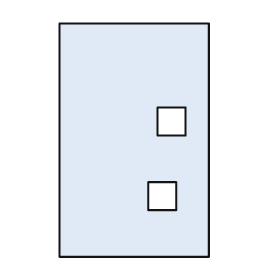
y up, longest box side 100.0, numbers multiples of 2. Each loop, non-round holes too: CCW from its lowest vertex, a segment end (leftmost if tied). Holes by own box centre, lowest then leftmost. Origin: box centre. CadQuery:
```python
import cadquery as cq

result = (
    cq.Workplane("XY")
    .moveTo(-32.0, -50.0)
    .lineTo(32.0, -50.0)
    .lineTo(32.0, 50.0)
    .lineTo(-32.0, 50.0)
    .close()
    .moveTo(6.0, -30.0)
    .lineTo(18.0, -30.0)
    .lineTo(18.0, -18.0)
    .lineTo(6.0, -18.0)
    .close()
    .moveTo(10.0, 2.0)
    .lineTo(22.0, 2.0)
    .lineTo(22.0, 14.0)
    .lineTo(10.0, 14.0)
    .close()
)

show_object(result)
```